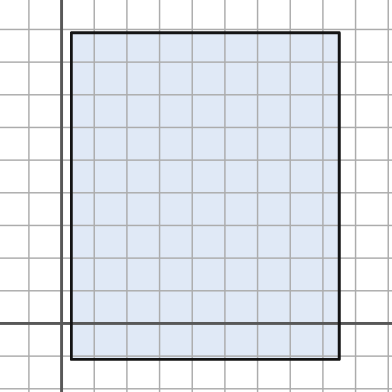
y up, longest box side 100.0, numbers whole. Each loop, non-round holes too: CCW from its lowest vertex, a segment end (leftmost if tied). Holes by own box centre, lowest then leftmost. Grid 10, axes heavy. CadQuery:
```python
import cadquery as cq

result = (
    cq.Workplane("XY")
    .moveTo(3.0, -11.0)
    .lineTo(85.0, -11.0)
    .lineTo(85.0, 89.0)
    .lineTo(3.0, 89.0)
    .close()
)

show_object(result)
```